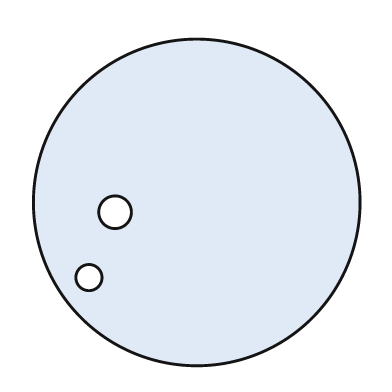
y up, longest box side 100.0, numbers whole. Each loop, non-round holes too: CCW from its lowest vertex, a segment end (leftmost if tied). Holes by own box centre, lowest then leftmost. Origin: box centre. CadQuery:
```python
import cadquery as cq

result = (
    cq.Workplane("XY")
    .moveTo(0.0, 0.0)
    .circle(50.0)
    .moveTo(-33.0, -23.0)
    .circle(4.0)
    .moveTo(-25.0, -3.0)
    .circle(5.0)
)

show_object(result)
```